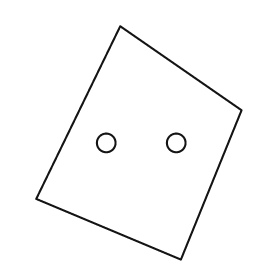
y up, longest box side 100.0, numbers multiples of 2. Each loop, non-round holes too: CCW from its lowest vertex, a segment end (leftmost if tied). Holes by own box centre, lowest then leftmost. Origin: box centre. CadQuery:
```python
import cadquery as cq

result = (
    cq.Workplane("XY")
    .moveTo(18.0, -50.0)
    .lineTo(44.0, 14.0)
    .lineTo(-8.0, 50.0)
    .lineTo(-44.0, -24.0)
    .close()
    .moveTo(-14.0, 0.0)
    .circle(4.0)
    .moveTo(16.0, 0.0)
    .circle(4.0)
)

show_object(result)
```